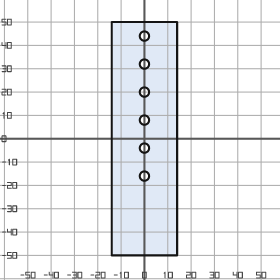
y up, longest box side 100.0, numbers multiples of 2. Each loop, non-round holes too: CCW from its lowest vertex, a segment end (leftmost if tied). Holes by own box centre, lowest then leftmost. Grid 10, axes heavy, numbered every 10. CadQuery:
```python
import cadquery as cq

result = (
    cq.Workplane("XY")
    .moveTo(-14.0, -50.0)
    .lineTo(14.0, -50.0)
    .lineTo(14.0, 50.0)
    .lineTo(-14.0, 50.0)
    .close()
    .moveTo(0.0, -16.0)
    .circle(2.0)
    .moveTo(0.0, -4.0)
    .circle(2.0)
    .moveTo(0.0, 8.0)
    .circle(2.0)
    .moveTo(0.0, 20.0)
    .circle(2.0)
    .moveTo(0.0, 32.0)
    .circle(2.0)
    .moveTo(0.0, 44.0)
    .circle(2.0)
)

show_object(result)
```